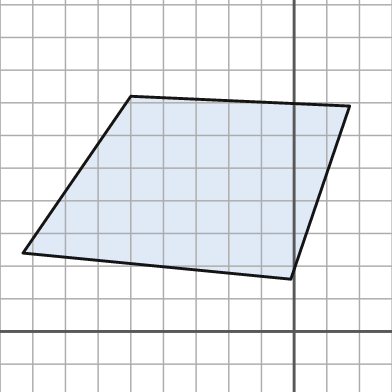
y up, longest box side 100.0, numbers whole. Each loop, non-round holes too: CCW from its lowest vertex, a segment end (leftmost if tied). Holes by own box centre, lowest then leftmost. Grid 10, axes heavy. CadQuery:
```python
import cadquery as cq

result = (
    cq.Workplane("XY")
    .moveTo(-1.0, 16.0)
    .lineTo(17.0, 69.0)
    .lineTo(-50.0, 72.0)
    .lineTo(-83.0, 24.0)
    .close()
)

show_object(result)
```